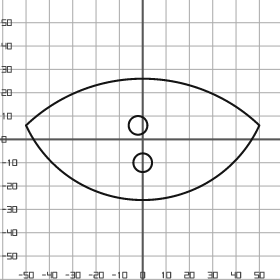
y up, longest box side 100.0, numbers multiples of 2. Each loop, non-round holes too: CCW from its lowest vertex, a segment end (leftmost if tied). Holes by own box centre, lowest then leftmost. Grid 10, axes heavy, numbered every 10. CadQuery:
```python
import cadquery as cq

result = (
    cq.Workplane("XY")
    .moveTo(-50.0, 6.0)
    .threePointArc((0.0, -26.0), (50.0, 6.0))
    .threePointArc((0.0, 26.0), (-50.0, 6.0))
    .close()
    .moveTo(0.0, -10.0)
    .circle(4.0)
    .moveTo(-2.0, 6.0)
    .circle(4.0)
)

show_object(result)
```